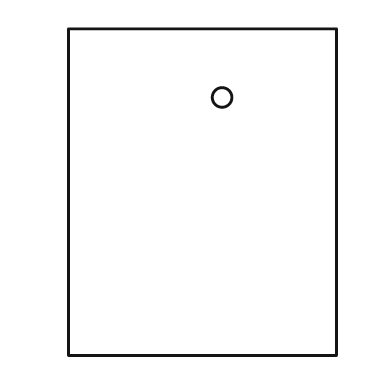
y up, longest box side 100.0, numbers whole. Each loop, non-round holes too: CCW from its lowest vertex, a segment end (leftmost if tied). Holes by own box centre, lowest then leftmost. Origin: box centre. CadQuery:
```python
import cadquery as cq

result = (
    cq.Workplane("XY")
    .moveTo(-41.0, -50.0)
    .lineTo(41.0, -50.0)
    .lineTo(41.0, 50.0)
    .lineTo(-41.0, 50.0)
    .close()
    .moveTo(6.0, 29.0)
    .circle(3.0)
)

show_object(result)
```